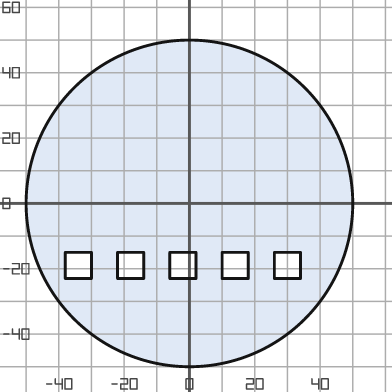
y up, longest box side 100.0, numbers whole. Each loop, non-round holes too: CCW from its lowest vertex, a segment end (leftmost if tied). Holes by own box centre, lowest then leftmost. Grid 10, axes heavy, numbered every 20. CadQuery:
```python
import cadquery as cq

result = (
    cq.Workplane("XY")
    .moveTo(0.0, 0.0)
    .circle(50.0)
    .moveTo(-38.0, -23.0)
    .lineTo(-30.0, -23.0)
    .lineTo(-30.0, -15.0)
    .lineTo(-38.0, -15.0)
    .close()
    .moveTo(-22.0, -23.0)
    .lineTo(-14.0, -23.0)
    .lineTo(-14.0, -15.0)
    .lineTo(-22.0, -15.0)
    .close()
    .moveTo(-6.0, -23.0)
    .lineTo(2.0, -23.0)
    .lineTo(2.0, -15.0)
    .lineTo(-6.0, -15.0)
    .close()
    .moveTo(10.0, -23.0)
    .lineTo(18.0, -23.0)
    .lineTo(18.0, -15.0)
    .lineTo(10.0, -15.0)
    .close()
    .moveTo(26.0, -23.0)
    .lineTo(34.0, -23.0)
    .lineTo(34.0, -15.0)
    .lineTo(26.0, -15.0)
    .close()
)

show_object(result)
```